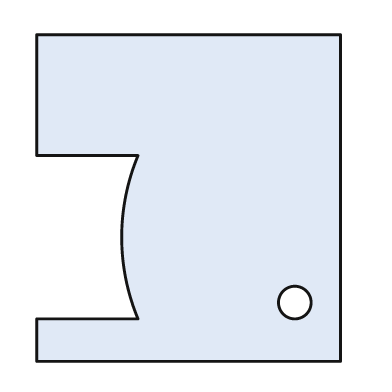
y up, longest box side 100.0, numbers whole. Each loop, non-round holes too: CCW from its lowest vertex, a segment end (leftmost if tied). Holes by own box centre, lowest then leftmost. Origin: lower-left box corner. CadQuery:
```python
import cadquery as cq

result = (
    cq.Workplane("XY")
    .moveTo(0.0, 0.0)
    .lineTo(93.0, 0.0)
    .lineTo(93.0, 100.0)
    .lineTo(0.0, 100.0)
    .lineTo(0.0, 63.0)
    .lineTo(31.0, 63.0)
    .threePointArc((26.0, 38.0), (31.0, 13.0))
    .lineTo(0.0, 13.0)
    .close()
    .moveTo(79.0, 18.0)
    .circle(5.0)
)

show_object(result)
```